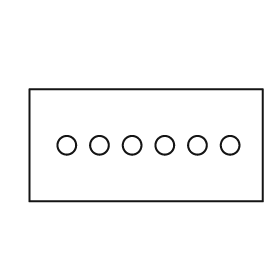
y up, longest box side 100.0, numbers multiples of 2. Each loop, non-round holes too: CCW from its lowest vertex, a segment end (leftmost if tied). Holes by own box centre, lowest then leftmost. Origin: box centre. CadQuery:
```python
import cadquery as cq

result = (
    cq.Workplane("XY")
    .moveTo(-50.0, -24.0)
    .lineTo(50.0, -24.0)
    .lineTo(50.0, 24.0)
    .lineTo(-50.0, 24.0)
    .close()
    .moveTo(-34.0, 0.0)
    .circle(4.0)
    .moveTo(-20.0, 0.0)
    .circle(4.0)
    .moveTo(-6.0, 0.0)
    .circle(4.0)
    .moveTo(8.0, 0.0)
    .circle(4.0)
    .moveTo(22.0, 0.0)
    .circle(4.0)
    .moveTo(36.0, 0.0)
    .circle(4.0)
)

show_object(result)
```